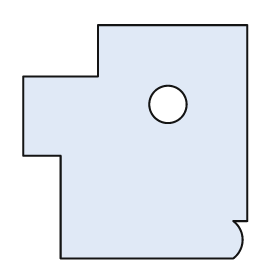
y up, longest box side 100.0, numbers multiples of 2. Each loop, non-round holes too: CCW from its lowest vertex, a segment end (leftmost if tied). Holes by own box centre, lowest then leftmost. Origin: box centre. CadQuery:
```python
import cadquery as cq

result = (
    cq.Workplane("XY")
    .moveTo(-32.0, -50.0)
    .lineTo(42.0, -50.0)
    .threePointArc((46.0, -42.0), (42.0, -34.0))
    .lineTo(48.0, -34.0)
    .lineTo(48.0, 50.0)
    .lineTo(-16.0, 50.0)
    .lineTo(-16.0, 28.0)
    .lineTo(-48.0, 28.0)
    .lineTo(-48.0, -6.0)
    .lineTo(-32.0, -6.0)
    .close()
    .moveTo(14.0, 16.0)
    .circle(8.0)
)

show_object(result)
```